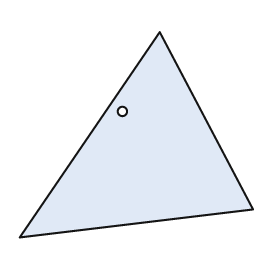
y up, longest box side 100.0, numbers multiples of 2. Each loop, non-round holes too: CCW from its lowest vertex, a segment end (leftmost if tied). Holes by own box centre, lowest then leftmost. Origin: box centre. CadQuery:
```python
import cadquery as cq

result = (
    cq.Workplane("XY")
    .moveTo(-50.0, -44.0)
    .lineTo(50.0, -32.0)
    .lineTo(10.0, 44.0)
    .close()
    .moveTo(-6.0, 10.0)
    .circle(2.0)
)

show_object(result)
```